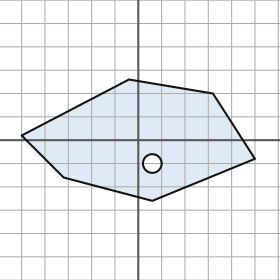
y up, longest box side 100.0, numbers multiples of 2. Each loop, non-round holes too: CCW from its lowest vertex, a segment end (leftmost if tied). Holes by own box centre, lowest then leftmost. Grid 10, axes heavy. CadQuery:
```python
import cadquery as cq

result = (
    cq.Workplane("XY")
    .moveTo(6.0, -26.0)
    .lineTo(50.0, -8.0)
    .lineTo(32.0, 20.0)
    .lineTo(-4.0, 26.0)
    .lineTo(-50.0, 2.0)
    .lineTo(-32.0, -16.0)
    .close()
    .moveTo(6.0, -10.0)
    .circle(4.0)
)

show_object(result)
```